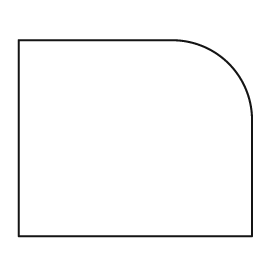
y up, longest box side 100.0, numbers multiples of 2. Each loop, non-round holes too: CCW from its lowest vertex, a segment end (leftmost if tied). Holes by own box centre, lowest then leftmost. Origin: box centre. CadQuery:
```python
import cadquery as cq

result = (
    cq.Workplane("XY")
    .moveTo(-50.0, -42.0)
    .lineTo(50.0, -42.0)
    .lineTo(50.0, 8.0)
    .threePointArc((40.0, 32.0), (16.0, 42.0))
    .lineTo(-50.0, 42.0)
    .close()
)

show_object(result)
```